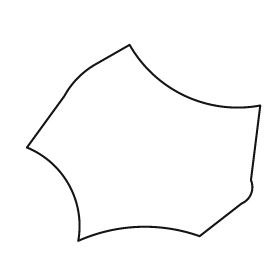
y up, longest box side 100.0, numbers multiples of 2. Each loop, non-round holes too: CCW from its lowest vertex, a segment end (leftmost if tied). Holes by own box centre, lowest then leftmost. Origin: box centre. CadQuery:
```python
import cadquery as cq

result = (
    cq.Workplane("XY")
    .moveTo(-28.0, -42.0)
    .threePointArc((-2.0, -36.0), (24.0, -40.0))
    .lineTo(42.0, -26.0)
    .threePointArc((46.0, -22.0), (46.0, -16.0))
    .lineTo(50.0, 16.0)
    .threePointArc((18.0, 20.0), (-6.0, 42.0))
    .lineTo(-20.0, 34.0)
    .threePointArc((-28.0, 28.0), (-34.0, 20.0))
    .lineTo(-50.0, -2.0)
    .threePointArc((-32.0, -18.0), (-28.0, -42.0))
    .close()
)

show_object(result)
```